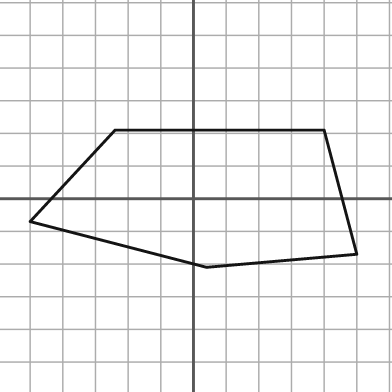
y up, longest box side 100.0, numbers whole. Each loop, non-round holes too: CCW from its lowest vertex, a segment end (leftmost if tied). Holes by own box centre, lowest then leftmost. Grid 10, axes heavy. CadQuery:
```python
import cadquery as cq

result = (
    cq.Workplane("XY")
    .moveTo(4.0, -21.0)
    .lineTo(50.0, -17.0)
    .lineTo(40.0, 21.0)
    .lineTo(-24.0, 21.0)
    .lineTo(-50.0, -7.0)
    .close()
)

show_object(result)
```